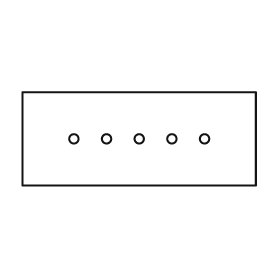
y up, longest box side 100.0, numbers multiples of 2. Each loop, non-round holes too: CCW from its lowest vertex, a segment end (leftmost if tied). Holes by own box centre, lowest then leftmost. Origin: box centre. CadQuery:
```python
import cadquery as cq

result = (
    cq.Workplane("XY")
    .moveTo(-50.0, -20.0)
    .lineTo(50.0, -20.0)
    .lineTo(50.0, 20.0)
    .lineTo(-50.0, 20.0)
    .close()
    .moveTo(-28.0, 0.0)
    .circle(2.0)
    .moveTo(-14.0, 0.0)
    .circle(2.0)
    .moveTo(0.0, 0.0)
    .circle(2.0)
    .moveTo(14.0, 0.0)
    .circle(2.0)
    .moveTo(28.0, 0.0)
    .circle(2.0)
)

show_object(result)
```